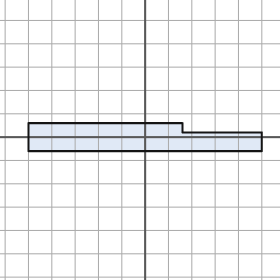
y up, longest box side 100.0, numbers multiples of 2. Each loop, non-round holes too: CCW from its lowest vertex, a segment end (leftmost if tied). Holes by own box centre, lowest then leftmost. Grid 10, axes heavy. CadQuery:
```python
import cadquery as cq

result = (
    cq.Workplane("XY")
    .moveTo(-50.0, -6.0)
    .lineTo(50.0, -6.0)
    .lineTo(50.0, 2.0)
    .lineTo(16.0, 2.0)
    .lineTo(16.0, 6.0)
    .lineTo(-50.0, 6.0)
    .close()
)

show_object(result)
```